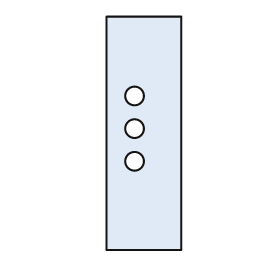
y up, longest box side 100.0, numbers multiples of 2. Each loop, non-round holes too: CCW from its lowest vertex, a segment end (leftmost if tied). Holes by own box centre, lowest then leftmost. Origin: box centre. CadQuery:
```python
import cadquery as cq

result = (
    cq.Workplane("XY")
    .moveTo(-16.0, -50.0)
    .lineTo(16.0, -50.0)
    .lineTo(16.0, 50.0)
    .lineTo(-16.0, 50.0)
    .close()
    .moveTo(-4.0, -12.0)
    .circle(4.0)
    .moveTo(-4.0, 2.0)
    .circle(4.0)
    .moveTo(-4.0, 16.0)
    .circle(4.0)
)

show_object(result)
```